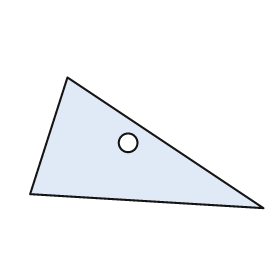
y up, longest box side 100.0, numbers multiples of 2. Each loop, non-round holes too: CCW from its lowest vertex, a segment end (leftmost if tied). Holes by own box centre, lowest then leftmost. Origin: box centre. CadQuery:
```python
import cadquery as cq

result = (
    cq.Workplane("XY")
    .moveTo(50.0, -28.0)
    .lineTo(-34.0, 28.0)
    .lineTo(-50.0, -22.0)
    .close()
    .moveTo(-8.0, 0.0)
    .circle(4.0)
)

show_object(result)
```